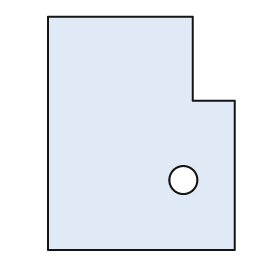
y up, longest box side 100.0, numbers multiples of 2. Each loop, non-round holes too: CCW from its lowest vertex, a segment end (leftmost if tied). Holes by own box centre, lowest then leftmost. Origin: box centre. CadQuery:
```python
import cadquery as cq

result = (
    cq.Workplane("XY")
    .moveTo(-40.0, -50.0)
    .lineTo(40.0, -50.0)
    .lineTo(40.0, 14.0)
    .lineTo(22.0, 14.0)
    .lineTo(22.0, 50.0)
    .lineTo(-40.0, 50.0)
    .close()
    .moveTo(18.0, -20.0)
    .circle(6.0)
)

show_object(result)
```